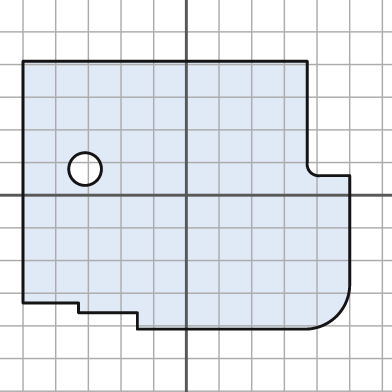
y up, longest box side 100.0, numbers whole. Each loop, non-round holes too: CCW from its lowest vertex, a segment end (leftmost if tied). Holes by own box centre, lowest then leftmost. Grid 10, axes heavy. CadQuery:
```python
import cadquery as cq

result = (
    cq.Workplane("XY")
    .moveTo(-15.0, -41.0)
    .lineTo(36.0, -41.0)
    .threePointArc((46.0, -37.0), (50.0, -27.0))
    .lineTo(50.0, 6.0)
    .lineTo(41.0, 6.0)
    .threePointArc((38.0, 7.0), (37.0, 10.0))
    .lineTo(37.0, 41.0)
    .lineTo(-50.0, 41.0)
    .lineTo(-50.0, -33.0)
    .lineTo(-33.0, -33.0)
    .lineTo(-33.0, -36.0)
    .lineTo(-15.0, -36.0)
    .close()
    .moveTo(-31.0, 8.0)
    .circle(5.0)
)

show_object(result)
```